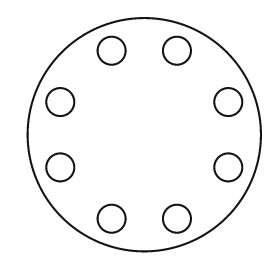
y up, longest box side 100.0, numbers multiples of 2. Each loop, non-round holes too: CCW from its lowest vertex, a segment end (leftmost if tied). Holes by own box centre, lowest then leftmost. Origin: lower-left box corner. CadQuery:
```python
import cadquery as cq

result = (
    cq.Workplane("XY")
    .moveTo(50.0, 50.0)
    .circle(50.0)
    .moveTo(36.0, 14.0)
    .circle(6.0)
    .moveTo(64.0, 14.0)
    .circle(6.0)
    .moveTo(14.0, 36.0)
    .circle(6.0)
    .moveTo(86.0, 36.0)
    .circle(6.0)
    .moveTo(14.0, 64.0)
    .circle(6.0)
    .moveTo(86.0, 64.0)
    .circle(6.0)
    .moveTo(36.0, 86.0)
    .circle(6.0)
    .moveTo(64.0, 86.0)
    .circle(6.0)
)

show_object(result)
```